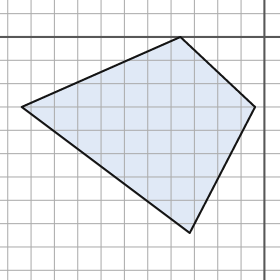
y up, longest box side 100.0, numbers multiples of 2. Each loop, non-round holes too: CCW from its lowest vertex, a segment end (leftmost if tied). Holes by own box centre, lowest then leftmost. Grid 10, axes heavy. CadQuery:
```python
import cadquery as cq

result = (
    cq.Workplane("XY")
    .moveTo(-32.0, -84.0)
    .lineTo(-4.0, -30.0)
    .lineTo(-36.0, 0.0)
    .lineTo(-104.0, -30.0)
    .close()
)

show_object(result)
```